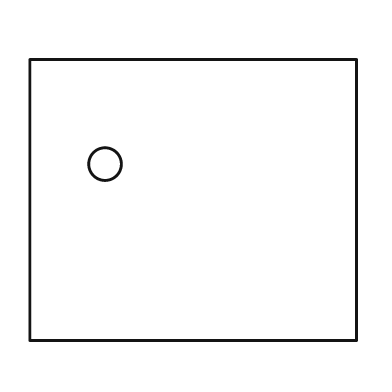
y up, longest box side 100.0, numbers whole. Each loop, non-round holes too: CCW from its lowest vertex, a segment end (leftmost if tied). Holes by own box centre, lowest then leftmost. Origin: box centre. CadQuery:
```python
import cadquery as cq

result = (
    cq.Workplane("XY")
    .moveTo(-50.0, -43.0)
    .lineTo(50.0, -43.0)
    .lineTo(50.0, 43.0)
    .lineTo(-50.0, 43.0)
    .close()
    .moveTo(-27.0, 11.0)
    .circle(5.0)
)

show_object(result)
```